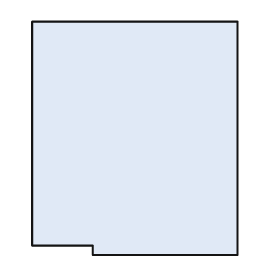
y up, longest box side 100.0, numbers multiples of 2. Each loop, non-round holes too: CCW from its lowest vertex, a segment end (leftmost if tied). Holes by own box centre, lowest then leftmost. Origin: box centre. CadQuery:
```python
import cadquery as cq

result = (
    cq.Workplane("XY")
    .moveTo(-18.0, -50.0)
    .lineTo(44.0, -50.0)
    .lineTo(44.0, 50.0)
    .lineTo(-44.0, 50.0)
    .lineTo(-44.0, -46.0)
    .lineTo(-18.0, -46.0)
    .close()
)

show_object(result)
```